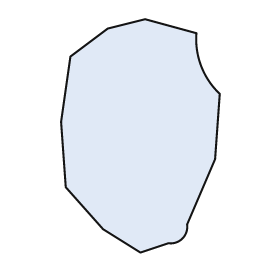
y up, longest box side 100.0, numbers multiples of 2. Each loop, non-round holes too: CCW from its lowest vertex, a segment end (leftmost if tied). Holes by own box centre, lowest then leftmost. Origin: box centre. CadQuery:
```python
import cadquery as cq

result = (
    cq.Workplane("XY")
    .moveTo(0.0, -50.0)
    .lineTo(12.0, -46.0)
    .threePointArc((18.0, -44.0), (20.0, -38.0))
    .lineTo(32.0, -10.0)
    .lineTo(34.0, 18.0)
    .threePointArc((26.0, 30.0), (24.0, 44.0))
    .lineTo(2.0, 50.0)
    .lineTo(-14.0, 46.0)
    .lineTo(-30.0, 34.0)
    .lineTo(-34.0, 6.0)
    .lineTo(-32.0, -22.0)
    .lineTo(-16.0, -40.0)
    .close()
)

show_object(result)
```